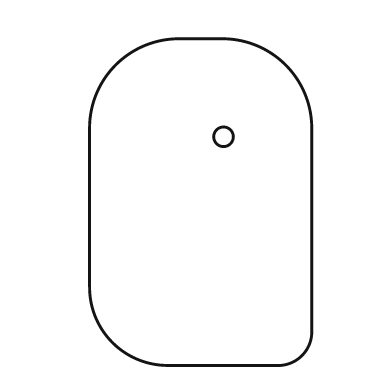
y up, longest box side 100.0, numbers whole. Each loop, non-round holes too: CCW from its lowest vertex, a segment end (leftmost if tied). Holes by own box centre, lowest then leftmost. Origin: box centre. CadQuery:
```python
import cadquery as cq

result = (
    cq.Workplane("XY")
    .moveTo(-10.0, -50.0)
    .lineTo(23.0, -50.0)
    .threePointArc((31.0, -47.0), (34.0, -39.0))
    .lineTo(34.0, 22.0)
    .threePointArc((26.0, 42.0), (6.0, 50.0))
    .lineTo(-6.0, 50.0)
    .threePointArc((-26.0, 42.0), (-34.0, 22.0))
    .lineTo(-34.0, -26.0)
    .threePointArc((-27.0, -43.0), (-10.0, -50.0))
    .close()
    .moveTo(7.0, 20.0)
    .circle(3.0)
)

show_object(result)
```